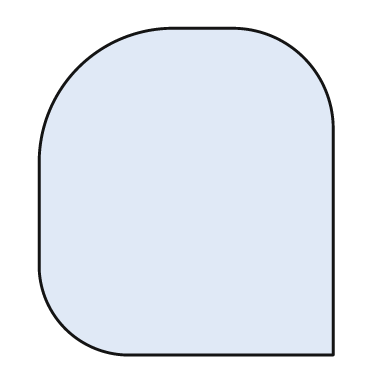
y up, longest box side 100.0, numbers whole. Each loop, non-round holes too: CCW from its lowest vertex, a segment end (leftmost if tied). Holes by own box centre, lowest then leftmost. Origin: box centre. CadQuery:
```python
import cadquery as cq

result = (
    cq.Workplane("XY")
    .moveTo(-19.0, -50.0)
    .lineTo(45.0, -50.0)
    .lineTo(45.0, 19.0)
    .threePointArc((36.0, 41.0), (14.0, 50.0))
    .lineTo(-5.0, 50.0)
    .threePointArc((-33.0, 38.0), (-45.0, 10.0))
    .lineTo(-45.0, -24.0)
    .threePointArc((-37.0, -42.0), (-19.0, -50.0))
    .close()
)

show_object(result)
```